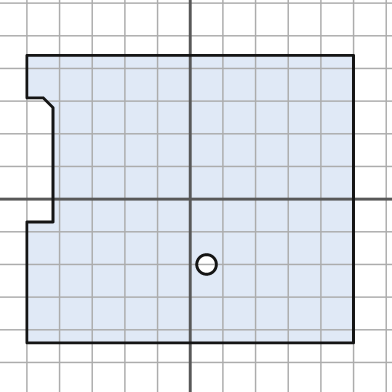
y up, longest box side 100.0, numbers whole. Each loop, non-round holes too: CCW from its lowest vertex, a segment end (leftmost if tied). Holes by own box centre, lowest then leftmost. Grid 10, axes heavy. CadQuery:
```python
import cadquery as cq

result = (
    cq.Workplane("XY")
    .moveTo(-50.0, -44.0)
    .lineTo(50.0, -44.0)
    .lineTo(50.0, 44.0)
    .lineTo(-50.0, 44.0)
    .lineTo(-50.0, 31.0)
    .lineTo(-45.0, 31.0)
    .lineTo(-42.0, 28.0)
    .lineTo(-42.0, -7.0)
    .lineTo(-50.0, -7.0)
    .close()
    .moveTo(5.0, -20.0)
    .circle(3.0)
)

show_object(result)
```